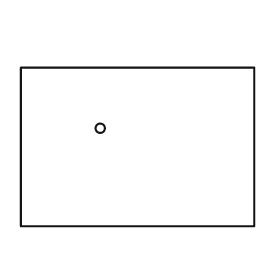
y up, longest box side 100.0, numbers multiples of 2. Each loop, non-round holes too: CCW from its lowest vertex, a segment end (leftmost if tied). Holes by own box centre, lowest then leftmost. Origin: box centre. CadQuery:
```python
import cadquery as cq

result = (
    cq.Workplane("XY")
    .moveTo(-50.0, -34.0)
    .lineTo(50.0, -34.0)
    .lineTo(50.0, 34.0)
    .lineTo(-50.0, 34.0)
    .close()
    .moveTo(-16.0, 8.0)
    .circle(2.0)
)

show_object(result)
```